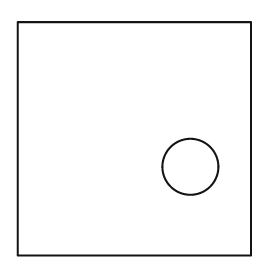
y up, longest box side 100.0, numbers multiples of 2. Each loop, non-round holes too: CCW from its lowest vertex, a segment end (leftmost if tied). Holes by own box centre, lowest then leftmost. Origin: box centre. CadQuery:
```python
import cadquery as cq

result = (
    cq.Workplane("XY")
    .moveTo(-50.0, -50.0)
    .lineTo(50.0, -50.0)
    .lineTo(50.0, 50.0)
    .lineTo(-50.0, 50.0)
    .close()
    .moveTo(24.0, -12.0)
    .circle(12.0)
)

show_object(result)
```